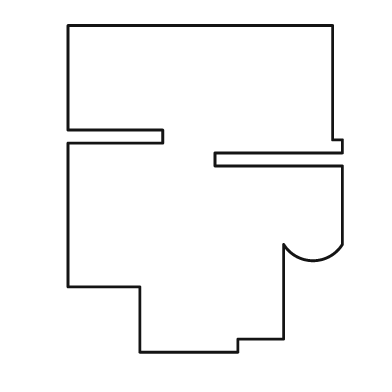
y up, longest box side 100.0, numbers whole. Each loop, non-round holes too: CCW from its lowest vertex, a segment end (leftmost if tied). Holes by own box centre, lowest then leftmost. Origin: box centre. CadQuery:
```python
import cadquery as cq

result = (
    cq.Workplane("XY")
    .moveTo(-20.0, -50.0)
    .lineTo(10.0, -50.0)
    .lineTo(10.0, -46.0)
    .lineTo(24.0, -46.0)
    .lineTo(24.0, -17.0)
    .threePointArc((33.0, -22.0), (42.0, -17.0))
    .lineTo(42.0, 7.0)
    .lineTo(3.0, 7.0)
    .lineTo(3.0, 11.0)
    .lineTo(42.0, 11.0)
    .lineTo(42.0, 15.0)
    .lineTo(39.0, 15.0)
    .lineTo(39.0, 50.0)
    .lineTo(-42.0, 50.0)
    .lineTo(-42.0, 18.0)
    .lineTo(-13.0, 18.0)
    .lineTo(-13.0, 14.0)
    .lineTo(-42.0, 14.0)
    .lineTo(-42.0, -30.0)
    .lineTo(-20.0, -30.0)
    .close()
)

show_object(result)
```